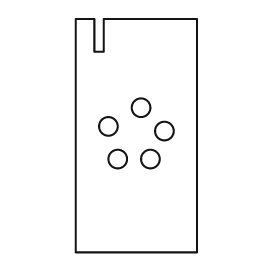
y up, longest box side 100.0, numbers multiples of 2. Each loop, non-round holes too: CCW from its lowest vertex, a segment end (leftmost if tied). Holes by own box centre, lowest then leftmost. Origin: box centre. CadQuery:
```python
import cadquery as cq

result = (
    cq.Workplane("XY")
    .moveTo(-26.0, -50.0)
    .lineTo(26.0, -50.0)
    .lineTo(26.0, 50.0)
    .lineTo(-14.0, 50.0)
    .lineTo(-14.0, 36.0)
    .lineTo(-18.0, 36.0)
    .lineTo(-18.0, 50.0)
    .lineTo(-26.0, 50.0)
    .close()
    .moveTo(-8.0, -10.0)
    .circle(4.0)
    .moveTo(6.0, -10.0)
    .circle(4.0)
    .moveTo(12.0, 2.0)
    .circle(4.0)
    .moveTo(-12.0, 4.0)
    .circle(4.0)
    .moveTo(2.0, 12.0)
    .circle(4.0)
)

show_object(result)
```